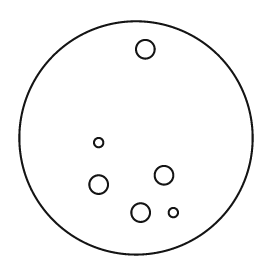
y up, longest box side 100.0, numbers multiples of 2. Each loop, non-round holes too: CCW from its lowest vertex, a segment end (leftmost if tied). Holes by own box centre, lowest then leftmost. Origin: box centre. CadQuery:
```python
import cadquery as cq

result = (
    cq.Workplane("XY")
    .moveTo(0.0, 0.0)
    .circle(50.0)
    .moveTo(2.0, -32.0)
    .circle(4.0)
    .moveTo(16.0, -32.0)
    .circle(2.0)
    .moveTo(-16.0, -20.0)
    .circle(4.0)
    .moveTo(12.0, -16.0)
    .circle(4.0)
    .moveTo(-16.0, -2.0)
    .circle(2.0)
    .moveTo(4.0, 38.0)
    .circle(4.0)
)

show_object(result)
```